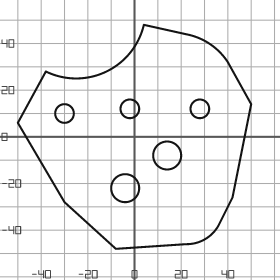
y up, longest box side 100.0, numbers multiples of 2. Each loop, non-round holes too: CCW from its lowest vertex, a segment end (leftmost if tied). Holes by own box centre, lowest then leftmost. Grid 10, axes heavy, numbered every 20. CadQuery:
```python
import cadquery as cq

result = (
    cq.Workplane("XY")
    .moveTo(-8.0, -48.0)
    .lineTo(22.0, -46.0)
    .threePointArc((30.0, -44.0), (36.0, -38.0))
    .lineTo(42.0, -26.0)
    .lineTo(50.0, 14.0)
    .lineTo(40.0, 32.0)
    .threePointArc((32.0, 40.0), (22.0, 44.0))
    .lineTo(4.0, 48.0)
    .threePointArc((-12.0, 28.0), (-38.0, 28.0))
    .lineTo(-50.0, 6.0)
    .lineTo(-30.0, -28.0)
    .close()
    .moveTo(-4.0, -22.0)
    .circle(6.0)
    .moveTo(14.0, -8.0)
    .circle(6.0)
    .moveTo(-30.0, 10.0)
    .circle(4.0)
    .moveTo(-2.0, 12.0)
    .circle(4.0)
    .moveTo(28.0, 12.0)
    .circle(4.0)
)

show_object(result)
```